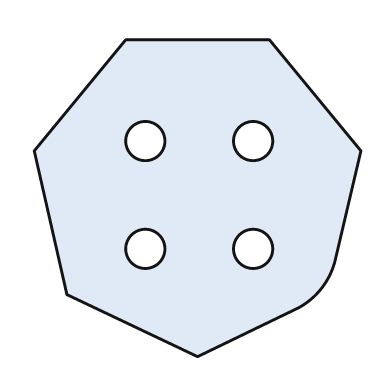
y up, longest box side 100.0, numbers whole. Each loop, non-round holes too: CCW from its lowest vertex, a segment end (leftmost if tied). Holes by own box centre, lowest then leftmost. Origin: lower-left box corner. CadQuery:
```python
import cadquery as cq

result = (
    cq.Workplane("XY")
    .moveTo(50.0, 0.0)
    .lineTo(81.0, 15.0)
    .threePointArc((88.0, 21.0), (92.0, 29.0))
    .lineTo(100.0, 63.0)
    .lineTo(72.0, 97.0)
    .lineTo(28.0, 97.0)
    .lineTo(0.0, 63.0)
    .lineTo(10.0, 19.0)
    .close()
    .moveTo(34.0, 33.0)
    .circle(6.0)
    .moveTo(67.0, 33.0)
    .circle(6.0)
    .moveTo(34.0, 66.0)
    .circle(6.0)
    .moveTo(67.0, 66.0)
    .circle(6.0)
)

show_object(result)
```